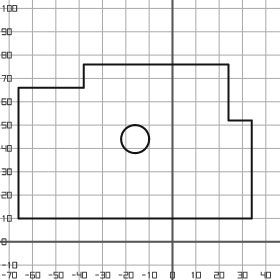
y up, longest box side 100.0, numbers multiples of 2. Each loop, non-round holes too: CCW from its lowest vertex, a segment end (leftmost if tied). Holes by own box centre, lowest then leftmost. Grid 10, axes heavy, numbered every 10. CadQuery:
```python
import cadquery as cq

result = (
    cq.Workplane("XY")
    .moveTo(-66.0, 10.0)
    .lineTo(34.0, 10.0)
    .lineTo(34.0, 52.0)
    .lineTo(24.0, 52.0)
    .lineTo(24.0, 76.0)
    .lineTo(-38.0, 76.0)
    .lineTo(-38.0, 66.0)
    .lineTo(-66.0, 66.0)
    .close()
    .moveTo(-16.0, 44.0)
    .circle(6.0)
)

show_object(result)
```